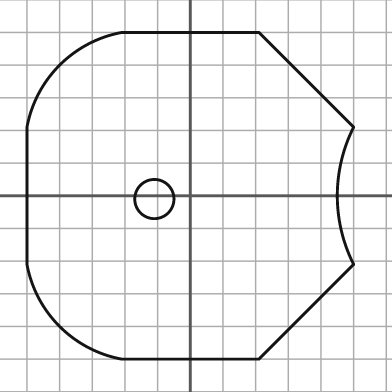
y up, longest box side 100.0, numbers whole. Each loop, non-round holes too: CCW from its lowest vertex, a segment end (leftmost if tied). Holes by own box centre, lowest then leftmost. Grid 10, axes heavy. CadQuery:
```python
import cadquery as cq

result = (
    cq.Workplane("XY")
    .moveTo(-21.0, -50.0)
    .lineTo(21.0, -50.0)
    .lineTo(50.0, -21.0)
    .threePointArc((45.0, 0.0), (50.0, 21.0))
    .lineTo(21.0, 50.0)
    .lineTo(-21.0, 50.0)
    .threePointArc((-40.0, 40.0), (-50.0, 21.0))
    .lineTo(-50.0, -21.0)
    .threePointArc((-40.0, -40.0), (-21.0, -50.0))
    .close()
    .moveTo(-11.0, -1.0)
    .circle(6.0)
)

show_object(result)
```